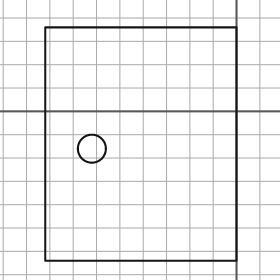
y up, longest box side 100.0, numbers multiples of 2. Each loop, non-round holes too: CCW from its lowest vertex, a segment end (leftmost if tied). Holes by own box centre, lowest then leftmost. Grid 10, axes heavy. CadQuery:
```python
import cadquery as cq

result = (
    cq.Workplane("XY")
    .moveTo(-82.0, -64.0)
    .lineTo(0.0, -64.0)
    .lineTo(0.0, 36.0)
    .lineTo(-82.0, 36.0)
    .close()
    .moveTo(-62.0, -16.0)
    .circle(6.0)
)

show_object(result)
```